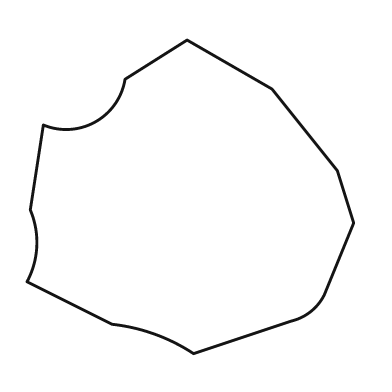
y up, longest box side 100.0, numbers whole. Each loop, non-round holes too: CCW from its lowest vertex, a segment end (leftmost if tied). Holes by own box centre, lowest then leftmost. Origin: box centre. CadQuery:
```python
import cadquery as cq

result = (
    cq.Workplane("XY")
    .moveTo(1.0, -48.0)
    .lineTo(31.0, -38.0)
    .threePointArc((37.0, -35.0), (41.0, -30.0))
    .lineTo(50.0, -8.0)
    .lineTo(45.0, 8.0)
    .lineTo(25.0, 33.0)
    .lineTo(-1.0, 48.0)
    .lineTo(-20.0, 36.0)
    .threePointArc((-29.0, 23.0), (-45.0, 22.0))
    .lineTo(-49.0, -4.0)
    .threePointArc((-47.0, -15.0), (-50.0, -26.0))
    .lineTo(-24.0, -39.0)
    .threePointArc((-11.0, -42.0), (1.0, -48.0))
    .close()
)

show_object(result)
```